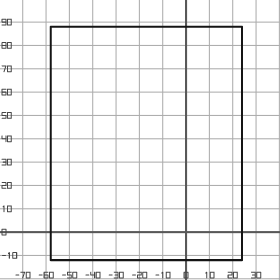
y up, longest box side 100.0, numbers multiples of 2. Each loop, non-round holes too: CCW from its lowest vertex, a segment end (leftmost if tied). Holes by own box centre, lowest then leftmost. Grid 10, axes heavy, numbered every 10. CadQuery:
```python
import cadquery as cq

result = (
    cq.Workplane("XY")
    .moveTo(-58.0, -12.0)
    .lineTo(24.0, -12.0)
    .lineTo(24.0, 88.0)
    .lineTo(-58.0, 88.0)
    .close()
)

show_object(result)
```